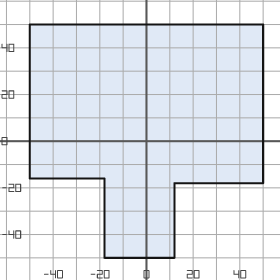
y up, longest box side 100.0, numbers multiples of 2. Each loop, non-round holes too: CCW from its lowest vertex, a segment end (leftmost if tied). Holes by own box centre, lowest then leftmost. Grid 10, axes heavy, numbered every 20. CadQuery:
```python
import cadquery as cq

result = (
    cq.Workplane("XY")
    .moveTo(-18.0, -50.0)
    .lineTo(12.0, -50.0)
    .lineTo(12.0, -18.0)
    .lineTo(50.0, -18.0)
    .lineTo(50.0, 50.0)
    .lineTo(-50.0, 50.0)
    .lineTo(-50.0, -16.0)
    .lineTo(-18.0, -16.0)
    .close()
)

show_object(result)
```